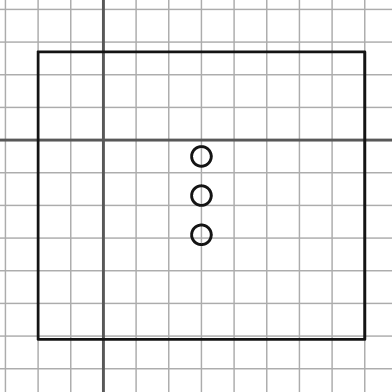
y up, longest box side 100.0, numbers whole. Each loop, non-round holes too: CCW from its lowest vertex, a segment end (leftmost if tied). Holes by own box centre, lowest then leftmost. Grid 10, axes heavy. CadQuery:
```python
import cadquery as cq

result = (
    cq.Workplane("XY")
    .moveTo(-20.0, -61.0)
    .lineTo(80.0, -61.0)
    .lineTo(80.0, 27.0)
    .lineTo(-20.0, 27.0)
    .close()
    .moveTo(30.0, -29.0)
    .circle(3.0)
    .moveTo(30.0, -17.0)
    .circle(3.0)
    .moveTo(30.0, -5.0)
    .circle(3.0)
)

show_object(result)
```